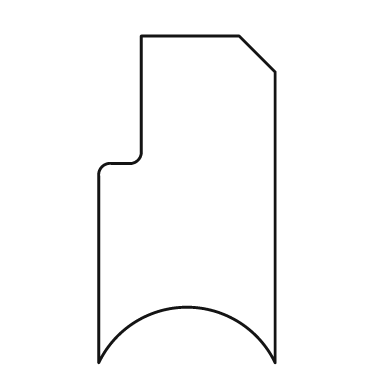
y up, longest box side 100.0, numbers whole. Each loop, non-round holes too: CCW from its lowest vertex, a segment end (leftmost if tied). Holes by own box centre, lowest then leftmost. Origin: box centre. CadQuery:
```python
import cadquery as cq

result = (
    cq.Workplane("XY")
    .moveTo(-27.0, -50.0)
    .threePointArc((0.0, -33.0), (27.0, -50.0))
    .lineTo(27.0, 39.0)
    .lineTo(16.0, 50.0)
    .lineTo(-14.0, 50.0)
    .lineTo(-14.0, 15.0)
    .threePointArc((-15.0, 12.0), (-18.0, 11.0))
    .lineTo(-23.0, 11.0)
    .threePointArc((-26.0, 10.0), (-27.0, 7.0))
    .close()
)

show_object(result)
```